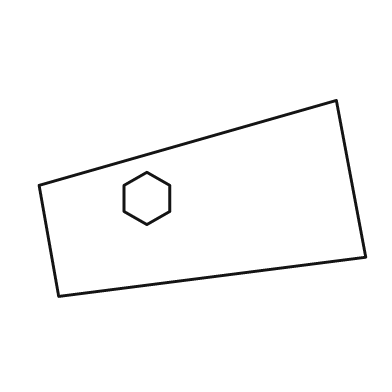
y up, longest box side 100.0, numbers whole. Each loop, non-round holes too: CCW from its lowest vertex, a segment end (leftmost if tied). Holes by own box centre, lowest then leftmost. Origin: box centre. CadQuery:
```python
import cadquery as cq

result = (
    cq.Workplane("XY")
    .moveTo(-44.0, -30.0)
    .lineTo(50.0, -18.0)
    .lineTo(41.0, 30.0)
    .lineTo(-50.0, 4.0)
    .close()
    .moveTo(-17.0, -8.0)
    .lineTo(-10.0, -4.0)
    .lineTo(-10.0, 4.0)
    .lineTo(-17.0, 8.0)
    .lineTo(-24.0, 4.0)
    .lineTo(-24.0, -4.0)
    .close()
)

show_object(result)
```